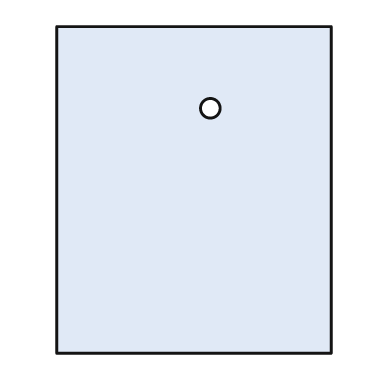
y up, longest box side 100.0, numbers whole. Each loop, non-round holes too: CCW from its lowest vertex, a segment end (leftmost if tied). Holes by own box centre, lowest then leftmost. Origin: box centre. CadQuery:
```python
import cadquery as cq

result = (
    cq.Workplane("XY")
    .moveTo(-42.0, -50.0)
    .lineTo(42.0, -50.0)
    .lineTo(42.0, 50.0)
    .lineTo(-42.0, 50.0)
    .close()
    .moveTo(5.0, 25.0)
    .circle(3.0)
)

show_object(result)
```